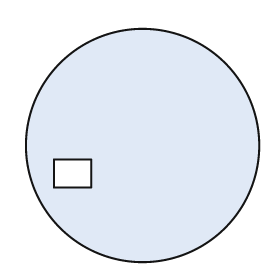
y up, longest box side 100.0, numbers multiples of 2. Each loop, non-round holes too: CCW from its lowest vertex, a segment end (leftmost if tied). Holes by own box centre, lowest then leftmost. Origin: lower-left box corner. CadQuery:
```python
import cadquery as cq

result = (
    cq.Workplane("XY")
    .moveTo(50.0, 50.0)
    .circle(50.0)
    .moveTo(12.0, 32.0)
    .lineTo(28.0, 32.0)
    .lineTo(28.0, 44.0)
    .lineTo(12.0, 44.0)
    .close()
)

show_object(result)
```